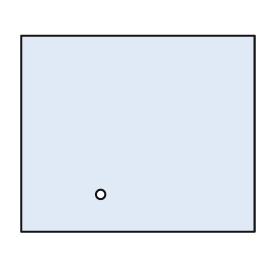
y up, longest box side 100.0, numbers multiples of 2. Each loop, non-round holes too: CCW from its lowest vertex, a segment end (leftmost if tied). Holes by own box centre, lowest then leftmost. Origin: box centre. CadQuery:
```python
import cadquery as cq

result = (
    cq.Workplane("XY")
    .moveTo(-50.0, -42.0)
    .lineTo(50.0, -42.0)
    .lineTo(50.0, 42.0)
    .lineTo(-50.0, 42.0)
    .close()
    .moveTo(-16.0, -26.0)
    .circle(2.0)
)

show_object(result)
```